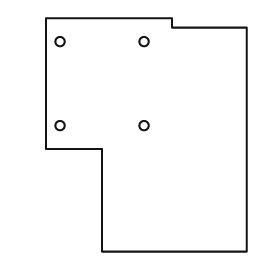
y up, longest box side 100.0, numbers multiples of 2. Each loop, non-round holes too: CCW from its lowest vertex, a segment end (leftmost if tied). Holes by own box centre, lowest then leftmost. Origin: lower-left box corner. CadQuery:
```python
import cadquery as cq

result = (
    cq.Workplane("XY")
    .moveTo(24.0, 0.0)
    .lineTo(86.0, 0.0)
    .lineTo(86.0, 96.0)
    .lineTo(54.0, 96.0)
    .lineTo(54.0, 100.0)
    .lineTo(0.0, 100.0)
    .lineTo(0.0, 44.0)
    .lineTo(24.0, 44.0)
    .close()
    .moveTo(6.0, 54.0)
    .circle(2.0)
    .moveTo(42.0, 54.0)
    .circle(2.0)
    .moveTo(6.0, 90.0)
    .circle(2.0)
    .moveTo(42.0, 90.0)
    .circle(2.0)
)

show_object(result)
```